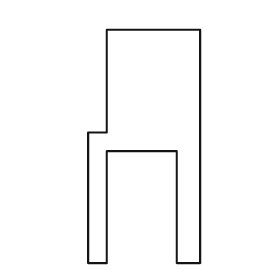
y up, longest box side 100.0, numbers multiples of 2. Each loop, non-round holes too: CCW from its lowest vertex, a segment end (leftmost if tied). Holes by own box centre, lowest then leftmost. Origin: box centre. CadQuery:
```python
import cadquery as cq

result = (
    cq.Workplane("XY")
    .moveTo(-24.0, -50.0)
    .lineTo(-16.0, -50.0)
    .lineTo(-16.0, -2.0)
    .lineTo(14.0, -2.0)
    .lineTo(14.0, -50.0)
    .lineTo(24.0, -50.0)
    .lineTo(24.0, 50.0)
    .lineTo(-16.0, 50.0)
    .lineTo(-16.0, 6.0)
    .lineTo(-24.0, 6.0)
    .close()
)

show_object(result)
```